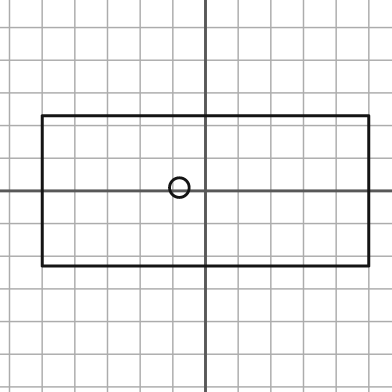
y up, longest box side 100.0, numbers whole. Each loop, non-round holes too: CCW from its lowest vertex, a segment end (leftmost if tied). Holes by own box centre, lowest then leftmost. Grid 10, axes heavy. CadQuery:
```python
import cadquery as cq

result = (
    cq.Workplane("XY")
    .moveTo(-50.0, -23.0)
    .lineTo(50.0, -23.0)
    .lineTo(50.0, 23.0)
    .lineTo(-50.0, 23.0)
    .close()
    .moveTo(-8.0, 1.0)
    .circle(3.0)
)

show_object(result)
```